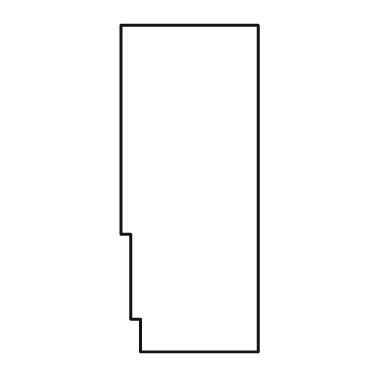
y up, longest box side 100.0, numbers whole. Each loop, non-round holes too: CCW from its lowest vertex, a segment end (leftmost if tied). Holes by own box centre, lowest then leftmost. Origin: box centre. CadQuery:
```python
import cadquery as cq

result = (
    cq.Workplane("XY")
    .moveTo(-15.0, -50.0)
    .lineTo(21.0, -50.0)
    .lineTo(21.0, 50.0)
    .lineTo(-21.0, 50.0)
    .lineTo(-21.0, -14.0)
    .lineTo(-18.0, -14.0)
    .lineTo(-18.0, -40.0)
    .lineTo(-15.0, -40.0)
    .close()
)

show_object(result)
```